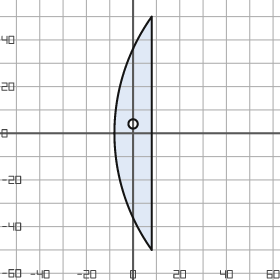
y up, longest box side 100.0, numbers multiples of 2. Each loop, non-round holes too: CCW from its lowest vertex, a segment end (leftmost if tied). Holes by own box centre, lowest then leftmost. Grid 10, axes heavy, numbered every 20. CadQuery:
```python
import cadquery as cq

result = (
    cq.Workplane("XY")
    .moveTo(8.0, -50.0)
    .lineTo(8.0, 50.0)
    .threePointArc((-8.0, 0.0), (8.0, -50.0))
    .close()
    .moveTo(0.0, 4.0)
    .circle(2.0)
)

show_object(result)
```